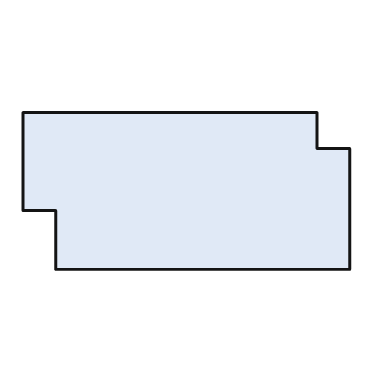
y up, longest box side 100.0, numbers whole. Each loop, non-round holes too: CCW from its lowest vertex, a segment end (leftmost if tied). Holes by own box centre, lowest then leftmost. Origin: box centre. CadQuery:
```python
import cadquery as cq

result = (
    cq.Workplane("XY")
    .moveTo(-40.0, -24.0)
    .lineTo(50.0, -24.0)
    .lineTo(50.0, 13.0)
    .lineTo(40.0, 13.0)
    .lineTo(40.0, 24.0)
    .lineTo(-50.0, 24.0)
    .lineTo(-50.0, -6.0)
    .lineTo(-40.0, -6.0)
    .close()
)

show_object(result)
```